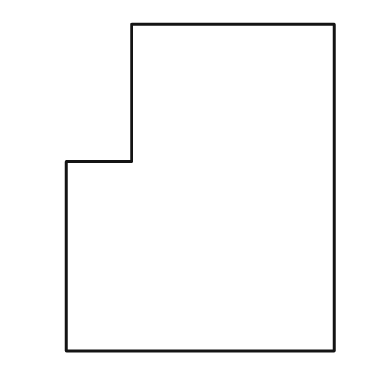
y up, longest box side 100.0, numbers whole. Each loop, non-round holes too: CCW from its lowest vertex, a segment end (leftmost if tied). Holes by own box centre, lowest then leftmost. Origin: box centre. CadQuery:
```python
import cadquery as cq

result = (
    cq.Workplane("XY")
    .moveTo(-41.0, -50.0)
    .lineTo(41.0, -50.0)
    .lineTo(41.0, 50.0)
    .lineTo(-21.0, 50.0)
    .lineTo(-21.0, 8.0)
    .lineTo(-41.0, 8.0)
    .close()
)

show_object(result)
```